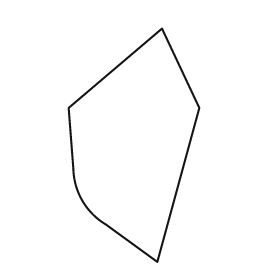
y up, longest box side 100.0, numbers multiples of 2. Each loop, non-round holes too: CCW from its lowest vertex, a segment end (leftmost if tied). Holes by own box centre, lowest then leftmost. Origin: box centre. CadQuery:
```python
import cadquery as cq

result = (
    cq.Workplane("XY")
    .moveTo(10.0, -50.0)
    .lineTo(28.0, 16.0)
    .lineTo(12.0, 50.0)
    .lineTo(-28.0, 16.0)
    .lineTo(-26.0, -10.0)
    .threePointArc((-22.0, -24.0), (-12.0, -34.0))
    .close()
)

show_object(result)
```